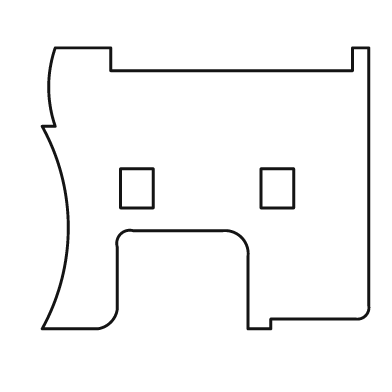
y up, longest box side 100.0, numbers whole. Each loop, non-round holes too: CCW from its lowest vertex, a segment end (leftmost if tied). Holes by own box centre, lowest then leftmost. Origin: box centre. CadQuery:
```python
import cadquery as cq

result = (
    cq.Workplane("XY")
    .moveTo(-50.0, -43.0)
    .lineTo(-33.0, -43.0)
    .threePointArc((-29.0, -41.0), (-27.0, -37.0))
    .lineTo(-27.0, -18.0)
    .threePointArc((-26.0, -14.0), (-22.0, -13.0))
    .lineTo(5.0, -13.0)
    .threePointArc((11.0, -15.0), (13.0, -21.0))
    .lineTo(13.0, -43.0)
    .lineTo(20.0, -43.0)
    .lineTo(20.0, -40.0)
    .lineTo(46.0, -40.0)
    .threePointArc((49.0, -39.0), (50.0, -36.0))
    .lineTo(50.0, 43.0)
    .lineTo(45.0, 43.0)
    .lineTo(45.0, 36.0)
    .lineTo(-29.0, 36.0)
    .lineTo(-29.0, 43.0)
    .lineTo(-46.0, 43.0)
    .threePointArc((-48.0, 31.0), (-46.0, 19.0))
    .lineTo(-50.0, 19.0)
    .threePointArc((-42.0, -12.0), (-50.0, -43.0))
    .close()
    .moveTo(-26.0, -6.0)
    .lineTo(-16.0, -6.0)
    .lineTo(-16.0, 6.0)
    .lineTo(-26.0, 6.0)
    .close()
    .moveTo(17.0, -6.0)
    .lineTo(27.0, -6.0)
    .lineTo(27.0, 6.0)
    .lineTo(17.0, 6.0)
    .close()
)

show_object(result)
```